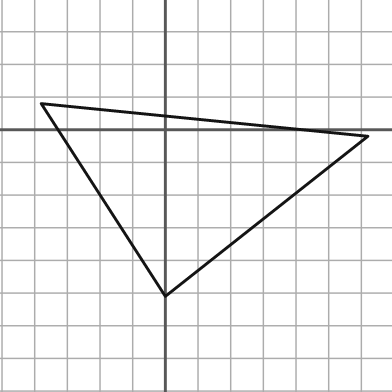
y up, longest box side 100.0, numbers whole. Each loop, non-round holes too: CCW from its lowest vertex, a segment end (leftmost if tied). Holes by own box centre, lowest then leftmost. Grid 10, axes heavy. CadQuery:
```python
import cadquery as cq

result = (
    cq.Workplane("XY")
    .moveTo(0.0, -51.0)
    .lineTo(62.0, -2.0)
    .lineTo(-38.0, 8.0)
    .close()
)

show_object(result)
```